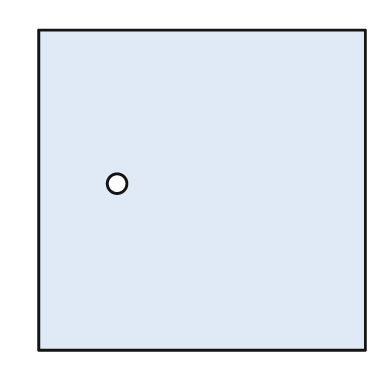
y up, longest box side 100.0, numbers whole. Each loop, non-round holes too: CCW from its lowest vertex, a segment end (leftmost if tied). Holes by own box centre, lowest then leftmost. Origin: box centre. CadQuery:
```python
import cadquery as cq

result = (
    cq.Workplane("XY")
    .moveTo(-50.0, -49.0)
    .lineTo(50.0, -49.0)
    .lineTo(50.0, 49.0)
    .lineTo(-50.0, 49.0)
    .close()
    .moveTo(-26.0, 2.0)
    .circle(3.0)
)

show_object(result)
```